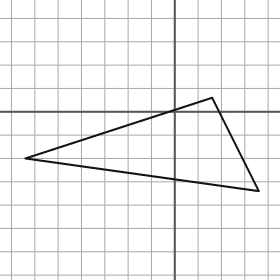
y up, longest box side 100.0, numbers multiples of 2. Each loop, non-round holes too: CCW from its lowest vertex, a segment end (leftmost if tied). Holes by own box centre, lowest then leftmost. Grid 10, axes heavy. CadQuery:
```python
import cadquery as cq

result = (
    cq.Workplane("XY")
    .moveTo(36.0, -34.0)
    .lineTo(16.0, 6.0)
    .lineTo(-64.0, -20.0)
    .close()
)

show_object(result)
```